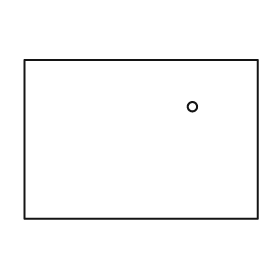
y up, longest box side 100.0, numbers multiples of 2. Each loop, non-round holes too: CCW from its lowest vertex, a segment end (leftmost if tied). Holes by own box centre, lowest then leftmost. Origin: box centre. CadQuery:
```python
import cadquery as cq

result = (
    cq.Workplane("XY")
    .moveTo(-50.0, -34.0)
    .lineTo(50.0, -34.0)
    .lineTo(50.0, 34.0)
    .lineTo(-50.0, 34.0)
    .close()
    .moveTo(22.0, 14.0)
    .circle(2.0)
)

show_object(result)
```